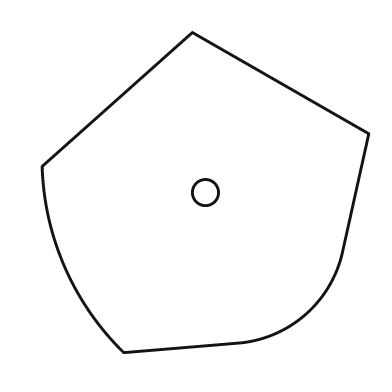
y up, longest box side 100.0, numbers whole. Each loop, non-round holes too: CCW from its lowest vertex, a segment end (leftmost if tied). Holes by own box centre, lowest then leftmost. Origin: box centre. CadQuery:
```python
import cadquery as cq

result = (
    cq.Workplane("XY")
    .moveTo(-25.0, -49.0)
    .lineTo(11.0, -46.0)
    .threePointArc((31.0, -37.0), (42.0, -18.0))
    .lineTo(50.0, 18.0)
    .lineTo(-4.0, 49.0)
    .lineTo(-50.0, 8.0)
    .threePointArc((-43.0, -23.0), (-25.0, -49.0))
    .close()
    .moveTo(0.0, 0.0)
    .circle(4.0)
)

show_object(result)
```